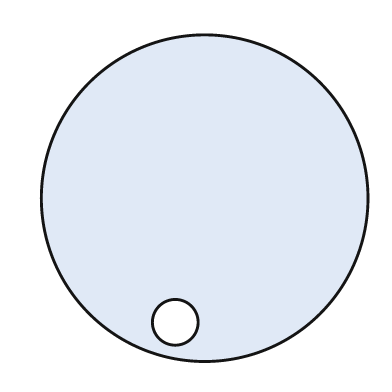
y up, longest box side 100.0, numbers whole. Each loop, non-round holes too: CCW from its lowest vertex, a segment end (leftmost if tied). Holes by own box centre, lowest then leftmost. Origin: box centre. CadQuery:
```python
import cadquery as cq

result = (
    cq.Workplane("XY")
    .moveTo(0.0, 0.0)
    .circle(50.0)
    .moveTo(-9.0, -38.0)
    .circle(7.0)
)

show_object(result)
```